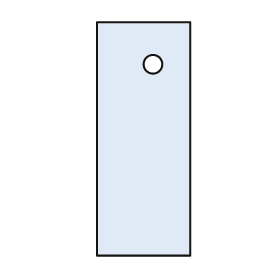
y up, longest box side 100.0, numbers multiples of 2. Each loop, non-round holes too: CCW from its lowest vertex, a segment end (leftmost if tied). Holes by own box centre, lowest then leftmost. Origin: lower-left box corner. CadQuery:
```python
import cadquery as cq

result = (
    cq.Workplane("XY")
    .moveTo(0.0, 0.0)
    .lineTo(40.0, 0.0)
    .lineTo(40.0, 100.0)
    .lineTo(0.0, 100.0)
    .close()
    .moveTo(24.0, 82.0)
    .circle(4.0)
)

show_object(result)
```